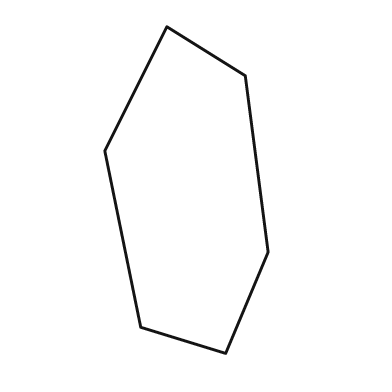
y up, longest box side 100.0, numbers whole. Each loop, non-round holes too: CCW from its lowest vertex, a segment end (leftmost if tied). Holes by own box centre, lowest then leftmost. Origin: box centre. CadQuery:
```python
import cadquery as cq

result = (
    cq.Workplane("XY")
    .moveTo(12.0, -50.0)
    .lineTo(25.0, -19.0)
    .lineTo(18.0, 35.0)
    .lineTo(-6.0, 50.0)
    .lineTo(-25.0, 12.0)
    .lineTo(-14.0, -42.0)
    .close()
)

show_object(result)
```